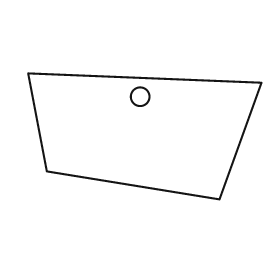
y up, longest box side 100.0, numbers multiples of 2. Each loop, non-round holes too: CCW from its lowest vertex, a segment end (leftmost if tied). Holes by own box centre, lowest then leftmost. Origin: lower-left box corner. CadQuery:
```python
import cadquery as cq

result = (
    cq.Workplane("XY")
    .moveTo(82.0, 0.0)
    .lineTo(100.0, 50.0)
    .lineTo(0.0, 54.0)
    .lineTo(8.0, 12.0)
    .close()
    .moveTo(48.0, 44.0)
    .circle(4.0)
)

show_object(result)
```